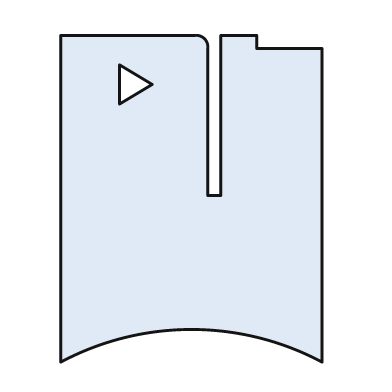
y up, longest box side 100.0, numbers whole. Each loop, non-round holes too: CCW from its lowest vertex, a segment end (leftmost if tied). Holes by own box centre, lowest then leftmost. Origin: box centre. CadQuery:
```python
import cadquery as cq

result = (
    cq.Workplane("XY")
    .moveTo(-40.0, -50.0)
    .threePointArc((0.0, -40.0), (40.0, -50.0))
    .lineTo(40.0, 46.0)
    .lineTo(20.0, 46.0)
    .lineTo(20.0, 50.0)
    .lineTo(9.0, 50.0)
    .lineTo(9.0, 1.0)
    .lineTo(5.0, 1.0)
    .lineTo(5.0, 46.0)
    .threePointArc((4.0, 49.0), (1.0, 50.0))
    .lineTo(-40.0, 50.0)
    .close()
    .moveTo(-22.0, 29.0)
    .lineTo(-12.0, 35.0)
    .lineTo(-22.0, 41.0)
    .close()
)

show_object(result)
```